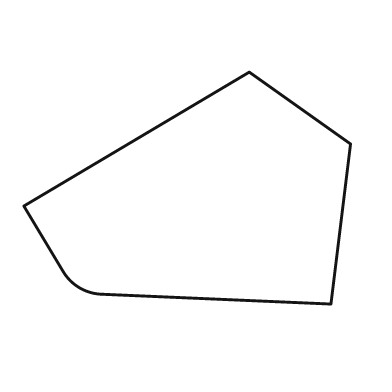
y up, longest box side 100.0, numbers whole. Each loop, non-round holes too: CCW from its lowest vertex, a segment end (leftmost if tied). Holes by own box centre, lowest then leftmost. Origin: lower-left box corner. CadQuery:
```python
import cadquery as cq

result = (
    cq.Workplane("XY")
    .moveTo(94.0, 0.0)
    .lineTo(100.0, 49.0)
    .lineTo(69.0, 71.0)
    .lineTo(0.0, 30.0)
    .lineTo(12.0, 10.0)
    .threePointArc((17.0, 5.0), (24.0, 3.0))
    .close()
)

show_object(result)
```